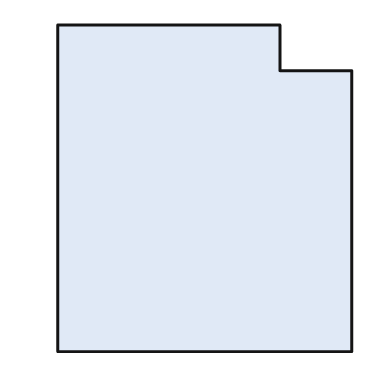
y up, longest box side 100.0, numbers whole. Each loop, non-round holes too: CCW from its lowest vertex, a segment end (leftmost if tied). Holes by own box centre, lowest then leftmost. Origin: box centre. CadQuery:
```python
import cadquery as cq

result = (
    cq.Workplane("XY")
    .moveTo(-45.0, -50.0)
    .lineTo(45.0, -50.0)
    .lineTo(45.0, 36.0)
    .lineTo(23.0, 36.0)
    .lineTo(23.0, 50.0)
    .lineTo(-45.0, 50.0)
    .close()
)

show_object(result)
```